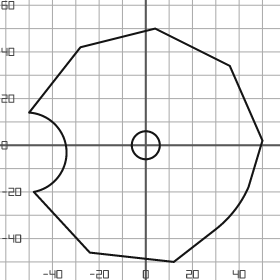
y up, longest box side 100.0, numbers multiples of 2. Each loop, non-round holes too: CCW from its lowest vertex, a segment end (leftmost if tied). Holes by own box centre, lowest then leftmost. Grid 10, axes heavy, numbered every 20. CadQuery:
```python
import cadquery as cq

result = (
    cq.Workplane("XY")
    .moveTo(12.0, -50.0)
    .lineTo(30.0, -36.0)
    .threePointArc((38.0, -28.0), (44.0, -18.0))
    .lineTo(50.0, 2.0)
    .lineTo(36.0, 34.0)
    .lineTo(4.0, 50.0)
    .lineTo(-28.0, 42.0)
    .lineTo(-50.0, 14.0)
    .threePointArc((-34.0, -2.0), (-48.0, -20.0))
    .lineTo(-24.0, -46.0)
    .close()
    .moveTo(0.0, 0.0)
    .circle(6.0)
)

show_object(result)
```